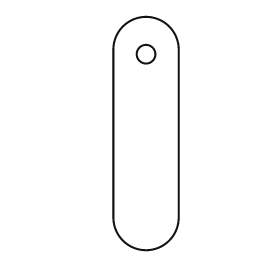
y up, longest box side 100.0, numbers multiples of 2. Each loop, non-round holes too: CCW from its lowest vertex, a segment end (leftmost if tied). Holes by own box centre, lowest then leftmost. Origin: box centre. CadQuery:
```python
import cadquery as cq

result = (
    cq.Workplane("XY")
    .moveTo(-14.0, -36.0)
    .threePointArc((0.0, -50.0), (14.0, -36.0))
    .lineTo(14.0, 36.0)
    .threePointArc((0.0, 50.0), (-14.0, 36.0))
    .close()
    .moveTo(0.0, 34.0)
    .circle(4.0)
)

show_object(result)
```